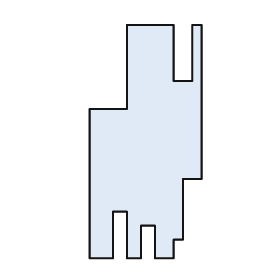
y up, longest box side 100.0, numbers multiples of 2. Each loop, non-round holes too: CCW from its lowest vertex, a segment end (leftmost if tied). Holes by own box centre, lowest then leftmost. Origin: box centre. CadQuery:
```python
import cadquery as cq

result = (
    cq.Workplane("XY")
    .moveTo(-24.0, -50.0)
    .lineTo(-14.0, -50.0)
    .lineTo(-14.0, -30.0)
    .lineTo(-8.0, -30.0)
    .lineTo(-8.0, -50.0)
    .lineTo(-2.0, -50.0)
    .lineTo(-2.0, -36.0)
    .lineTo(4.0, -36.0)
    .lineTo(4.0, -50.0)
    .lineTo(12.0, -50.0)
    .lineTo(12.0, -42.0)
    .lineTo(16.0, -42.0)
    .lineTo(16.0, -16.0)
    .lineTo(24.0, -16.0)
    .lineTo(24.0, 50.0)
    .lineTo(20.0, 50.0)
    .lineTo(20.0, 26.0)
    .lineTo(12.0, 26.0)
    .lineTo(12.0, 50.0)
    .lineTo(-8.0, 50.0)
    .lineTo(-8.0, 14.0)
    .lineTo(-24.0, 14.0)
    .close()
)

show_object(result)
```